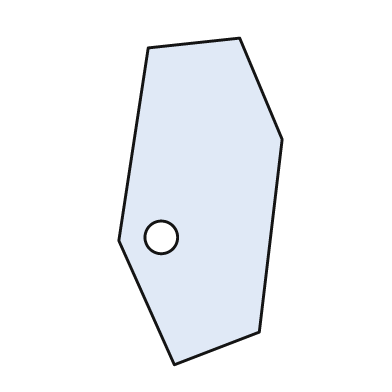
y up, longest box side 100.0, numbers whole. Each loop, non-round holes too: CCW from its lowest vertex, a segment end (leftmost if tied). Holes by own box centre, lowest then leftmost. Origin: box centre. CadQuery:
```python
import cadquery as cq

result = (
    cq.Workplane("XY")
    .moveTo(-8.0, -50.0)
    .lineTo(18.0, -40.0)
    .lineTo(25.0, 19.0)
    .lineTo(12.0, 50.0)
    .lineTo(-16.0, 47.0)
    .lineTo(-25.0, -12.0)
    .close()
    .moveTo(-12.0, -11.0)
    .circle(5.0)
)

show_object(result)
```